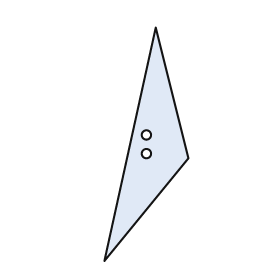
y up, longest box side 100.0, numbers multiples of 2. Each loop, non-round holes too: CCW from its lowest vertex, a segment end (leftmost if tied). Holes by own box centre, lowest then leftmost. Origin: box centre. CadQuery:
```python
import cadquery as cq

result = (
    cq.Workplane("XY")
    .moveTo(-18.0, -50.0)
    .lineTo(18.0, -6.0)
    .lineTo(4.0, 50.0)
    .close()
    .moveTo(0.0, -4.0)
    .circle(2.0)
    .moveTo(0.0, 4.0)
    .circle(2.0)
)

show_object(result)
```